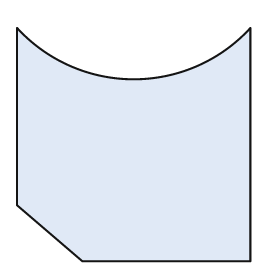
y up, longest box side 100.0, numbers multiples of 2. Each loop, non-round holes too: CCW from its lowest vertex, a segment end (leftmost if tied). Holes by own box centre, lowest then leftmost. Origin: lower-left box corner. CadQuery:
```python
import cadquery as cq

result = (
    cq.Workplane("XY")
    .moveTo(28.0, 0.0)
    .lineTo(100.0, 0.0)
    .lineTo(100.0, 100.0)
    .threePointArc((50.0, 78.0), (0.0, 100.0))
    .lineTo(0.0, 24.0)
    .close()
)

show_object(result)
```